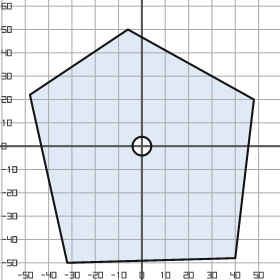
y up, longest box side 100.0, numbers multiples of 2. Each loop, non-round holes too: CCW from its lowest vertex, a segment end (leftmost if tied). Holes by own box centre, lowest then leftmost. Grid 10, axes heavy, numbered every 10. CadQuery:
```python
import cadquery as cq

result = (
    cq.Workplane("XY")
    .moveTo(-32.0, -50.0)
    .lineTo(40.0, -48.0)
    .lineTo(48.0, 20.0)
    .lineTo(-6.0, 50.0)
    .lineTo(-48.0, 22.0)
    .close()
    .moveTo(0.0, 0.0)
    .circle(4.0)
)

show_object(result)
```